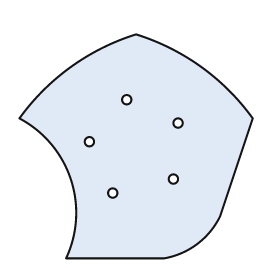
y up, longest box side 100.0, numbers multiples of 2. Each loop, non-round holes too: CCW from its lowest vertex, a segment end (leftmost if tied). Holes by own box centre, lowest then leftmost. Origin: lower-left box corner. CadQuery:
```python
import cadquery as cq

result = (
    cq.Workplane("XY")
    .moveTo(20.0, 0.0)
    .lineTo(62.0, 0.0)
    .threePointArc((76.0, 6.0), (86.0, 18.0))
    .lineTo(100.0, 60.0)
    .threePointArc((78.0, 82.0), (50.0, 96.0))
    .threePointArc((22.0, 82.0), (0.0, 60.0))
    .threePointArc((22.0, 34.0), (20.0, 0.0))
    .close()
    .moveTo(40.0, 28.0)
    .circle(2.0)
    .moveTo(66.0, 34.0)
    .circle(2.0)
    .moveTo(30.0, 50.0)
    .circle(2.0)
    .moveTo(68.0, 58.0)
    .circle(2.0)
    .moveTo(46.0, 68.0)
    .circle(2.0)
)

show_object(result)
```